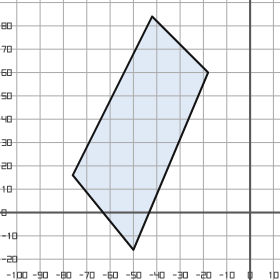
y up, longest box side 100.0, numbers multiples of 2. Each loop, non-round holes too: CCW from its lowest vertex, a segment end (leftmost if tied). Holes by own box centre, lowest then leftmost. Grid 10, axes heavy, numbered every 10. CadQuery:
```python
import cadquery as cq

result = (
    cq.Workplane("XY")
    .moveTo(-50.0, -16.0)
    .lineTo(-18.0, 60.0)
    .lineTo(-42.0, 84.0)
    .lineTo(-76.0, 16.0)
    .close()
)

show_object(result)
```